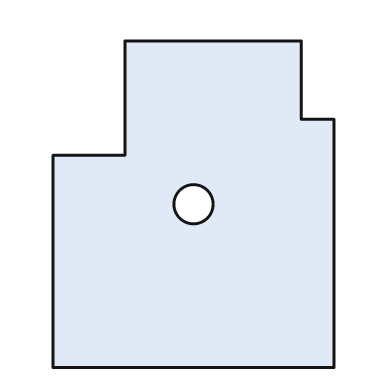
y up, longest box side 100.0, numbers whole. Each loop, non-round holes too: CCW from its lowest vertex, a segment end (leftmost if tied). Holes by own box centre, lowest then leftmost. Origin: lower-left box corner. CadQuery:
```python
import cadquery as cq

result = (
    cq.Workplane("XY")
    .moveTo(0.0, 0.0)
    .lineTo(86.0, 0.0)
    .lineTo(86.0, 76.0)
    .lineTo(76.0, 76.0)
    .lineTo(76.0, 100.0)
    .lineTo(22.0, 100.0)
    .lineTo(22.0, 65.0)
    .lineTo(0.0, 65.0)
    .close()
    .moveTo(43.0, 50.0)
    .circle(6.0)
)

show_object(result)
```